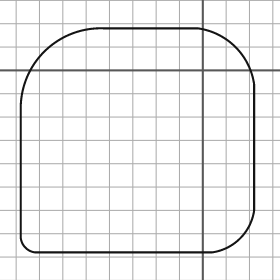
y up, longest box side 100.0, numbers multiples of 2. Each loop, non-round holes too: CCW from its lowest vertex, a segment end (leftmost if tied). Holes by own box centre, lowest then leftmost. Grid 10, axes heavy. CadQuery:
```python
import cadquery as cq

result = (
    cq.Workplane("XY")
    .moveTo(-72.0, -78.0)
    .lineTo(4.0, -78.0)
    .threePointArc((16.0, -72.0), (22.0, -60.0))
    .lineTo(22.0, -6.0)
    .threePointArc((14.0, 10.0), (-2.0, 18.0))
    .lineTo(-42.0, 18.0)
    .threePointArc((-68.0, 8.0), (-78.0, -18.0))
    .lineTo(-78.0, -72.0)
    .threePointArc((-76.0, -76.0), (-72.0, -78.0))
    .close()
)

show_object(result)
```